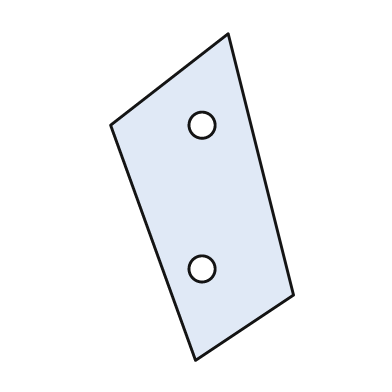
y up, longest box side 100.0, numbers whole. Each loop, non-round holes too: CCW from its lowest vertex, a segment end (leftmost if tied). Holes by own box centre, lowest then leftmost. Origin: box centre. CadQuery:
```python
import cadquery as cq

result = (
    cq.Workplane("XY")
    .moveTo(-2.0, -50.0)
    .lineTo(28.0, -30.0)
    .lineTo(8.0, 50.0)
    .lineTo(-28.0, 22.0)
    .close()
    .moveTo(0.0, -22.0)
    .circle(4.0)
    .moveTo(0.0, 22.0)
    .circle(4.0)
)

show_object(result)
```